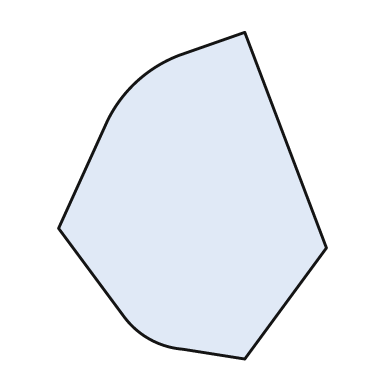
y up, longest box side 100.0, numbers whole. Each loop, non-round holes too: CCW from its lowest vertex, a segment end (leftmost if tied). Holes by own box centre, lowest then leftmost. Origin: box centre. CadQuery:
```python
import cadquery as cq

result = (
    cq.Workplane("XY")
    .moveTo(16.0, -50.0)
    .lineTo(41.0, -16.0)
    .lineTo(16.0, 50.0)
    .lineTo(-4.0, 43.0)
    .threePointArc((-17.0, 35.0), (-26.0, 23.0))
    .lineTo(-41.0, -10.0)
    .lineTo(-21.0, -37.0)
    .threePointArc((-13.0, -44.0), (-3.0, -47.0))
    .close()
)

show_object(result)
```